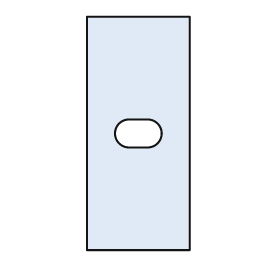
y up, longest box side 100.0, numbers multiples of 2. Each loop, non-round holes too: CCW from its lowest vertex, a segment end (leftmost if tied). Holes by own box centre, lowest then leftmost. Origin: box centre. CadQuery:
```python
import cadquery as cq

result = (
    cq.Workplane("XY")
    .moveTo(-22.0, -50.0)
    .lineTo(22.0, -50.0)
    .lineTo(22.0, 50.0)
    .lineTo(-22.0, 50.0)
    .close()
    .moveTo(-4.0, -6.0)
    .lineTo(4.0, -6.0)
    .threePointArc((10.0, 0.0), (4.0, 6.0))
    .lineTo(-4.0, 6.0)
    .threePointArc((-10.0, 0.0), (-4.0, -6.0))
    .close()
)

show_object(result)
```